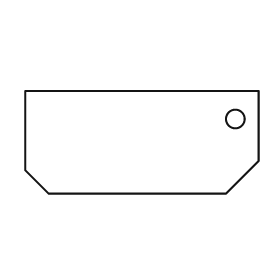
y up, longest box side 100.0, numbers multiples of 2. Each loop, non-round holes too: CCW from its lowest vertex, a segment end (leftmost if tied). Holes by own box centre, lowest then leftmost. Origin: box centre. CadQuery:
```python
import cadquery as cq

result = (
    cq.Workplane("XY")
    .moveTo(-40.0, -22.0)
    .lineTo(36.0, -22.0)
    .lineTo(50.0, -8.0)
    .lineTo(50.0, 22.0)
    .lineTo(-50.0, 22.0)
    .lineTo(-50.0, -12.0)
    .close()
    .moveTo(40.0, 10.0)
    .circle(4.0)
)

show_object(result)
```